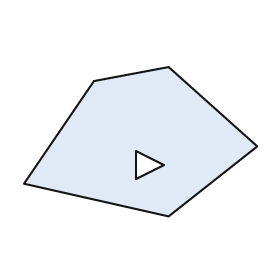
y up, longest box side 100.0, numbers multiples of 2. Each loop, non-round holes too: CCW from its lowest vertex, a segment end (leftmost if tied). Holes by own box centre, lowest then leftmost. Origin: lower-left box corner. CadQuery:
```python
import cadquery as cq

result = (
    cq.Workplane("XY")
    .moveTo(62.0, 0.0)
    .lineTo(100.0, 30.0)
    .lineTo(62.0, 64.0)
    .lineTo(30.0, 58.0)
    .lineTo(0.0, 14.0)
    .close()
    .moveTo(48.0, 16.0)
    .lineTo(60.0, 22.0)
    .lineTo(48.0, 28.0)
    .close()
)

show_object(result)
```